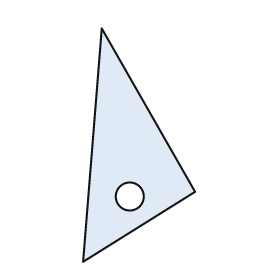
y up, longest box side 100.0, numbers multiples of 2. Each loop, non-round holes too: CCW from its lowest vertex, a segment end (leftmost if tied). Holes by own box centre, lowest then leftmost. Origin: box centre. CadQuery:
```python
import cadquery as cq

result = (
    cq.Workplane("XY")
    .moveTo(-24.0, -50.0)
    .lineTo(24.0, -20.0)
    .lineTo(-16.0, 50.0)
    .close()
    .moveTo(-4.0, -22.0)
    .circle(6.0)
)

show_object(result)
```